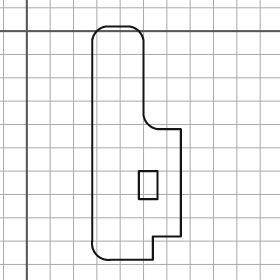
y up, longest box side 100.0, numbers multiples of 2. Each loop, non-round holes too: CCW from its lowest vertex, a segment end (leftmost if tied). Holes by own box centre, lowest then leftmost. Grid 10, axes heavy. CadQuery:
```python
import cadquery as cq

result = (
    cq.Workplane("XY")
    .moveTo(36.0, -98.0)
    .lineTo(54.0, -98.0)
    .lineTo(54.0, -88.0)
    .lineTo(66.0, -88.0)
    .lineTo(66.0, -42.0)
    .lineTo(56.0, -42.0)
    .threePointArc((52.0, -40.0), (50.0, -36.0))
    .lineTo(50.0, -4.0)
    .threePointArc((48.0, 0.0), (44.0, 2.0))
    .lineTo(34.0, 2.0)
    .threePointArc((30.0, 0.0), (28.0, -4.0))
    .lineTo(28.0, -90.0)
    .threePointArc((30.0, -96.0), (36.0, -98.0))
    .close()
    .moveTo(48.0, -72.0)
    .lineTo(56.0, -72.0)
    .lineTo(56.0, -60.0)
    .lineTo(48.0, -60.0)
    .close()
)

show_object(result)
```